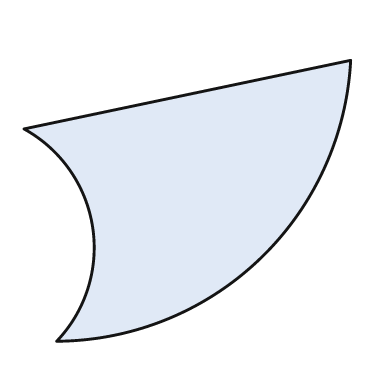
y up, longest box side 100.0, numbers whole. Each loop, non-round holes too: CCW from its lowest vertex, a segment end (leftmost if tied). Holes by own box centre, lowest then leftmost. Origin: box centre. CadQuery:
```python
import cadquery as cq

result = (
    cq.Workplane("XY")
    .moveTo(-40.0, -43.0)
    .threePointArc((22.0, -18.0), (50.0, 43.0))
    .lineTo(-50.0, 22.0)
    .threePointArc((-29.0, -8.0), (-40.0, -43.0))
    .close()
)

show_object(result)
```